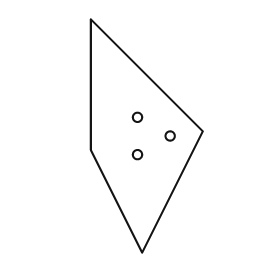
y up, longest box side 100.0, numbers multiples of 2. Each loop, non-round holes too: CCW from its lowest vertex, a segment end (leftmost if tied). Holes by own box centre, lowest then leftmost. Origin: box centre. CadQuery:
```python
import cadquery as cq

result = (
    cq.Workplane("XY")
    .moveTo(-2.0, -50.0)
    .lineTo(24.0, 2.0)
    .lineTo(-24.0, 50.0)
    .lineTo(-24.0, -6.0)
    .close()
    .moveTo(-4.0, -8.0)
    .circle(2.0)
    .moveTo(10.0, 0.0)
    .circle(2.0)
    .moveTo(-4.0, 8.0)
    .circle(2.0)
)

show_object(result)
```